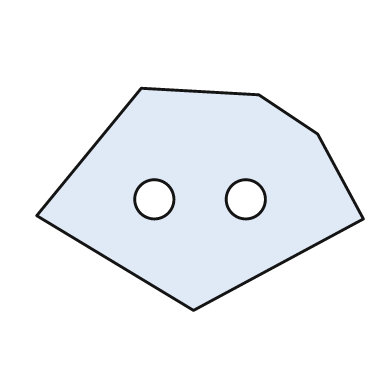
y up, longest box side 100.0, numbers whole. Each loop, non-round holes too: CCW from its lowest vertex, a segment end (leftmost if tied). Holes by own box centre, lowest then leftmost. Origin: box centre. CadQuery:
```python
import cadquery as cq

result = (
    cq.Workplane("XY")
    .moveTo(-2.0, -34.0)
    .lineTo(50.0, -6.0)
    .lineTo(36.0, 20.0)
    .lineTo(18.0, 32.0)
    .lineTo(-18.0, 34.0)
    .lineTo(-50.0, -5.0)
    .close()
    .moveTo(-14.0, 0.0)
    .circle(6.0)
    .moveTo(14.0, 0.0)
    .circle(6.0)
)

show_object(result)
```